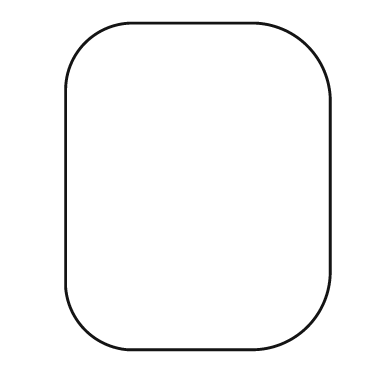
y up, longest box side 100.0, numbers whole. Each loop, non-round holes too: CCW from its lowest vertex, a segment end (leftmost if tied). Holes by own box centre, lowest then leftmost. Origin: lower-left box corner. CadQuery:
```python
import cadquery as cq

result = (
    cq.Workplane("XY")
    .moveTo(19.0, 0.0)
    .lineTo(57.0, 0.0)
    .threePointArc((74.0, 7.0), (81.0, 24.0))
    .lineTo(81.0, 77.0)
    .threePointArc((74.0, 93.0), (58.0, 100.0))
    .lineTo(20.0, 100.0)
    .threePointArc((6.0, 94.0), (0.0, 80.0))
    .lineTo(0.0, 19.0)
    .threePointArc((6.0, 6.0), (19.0, 0.0))
    .close()
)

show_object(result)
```